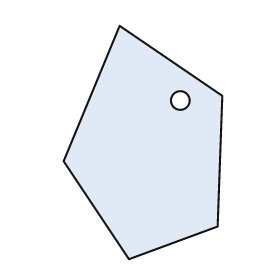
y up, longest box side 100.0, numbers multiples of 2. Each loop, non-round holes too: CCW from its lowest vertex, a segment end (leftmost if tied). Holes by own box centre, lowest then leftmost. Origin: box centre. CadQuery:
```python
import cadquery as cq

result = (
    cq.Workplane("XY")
    .moveTo(-6.0, -50.0)
    .lineTo(32.0, -36.0)
    .lineTo(34.0, 20.0)
    .lineTo(-10.0, 50.0)
    .lineTo(-34.0, -8.0)
    .close()
    .moveTo(16.0, 18.0)
    .circle(4.0)
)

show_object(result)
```